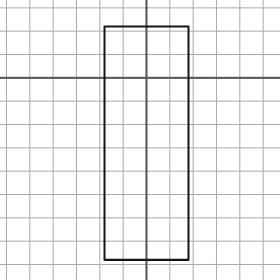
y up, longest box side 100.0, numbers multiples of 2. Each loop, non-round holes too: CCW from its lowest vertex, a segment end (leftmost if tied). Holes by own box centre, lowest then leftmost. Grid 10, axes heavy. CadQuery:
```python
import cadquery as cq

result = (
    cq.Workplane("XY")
    .moveTo(-18.0, -78.0)
    .lineTo(18.0, -78.0)
    .lineTo(18.0, 22.0)
    .lineTo(-18.0, 22.0)
    .close()
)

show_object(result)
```